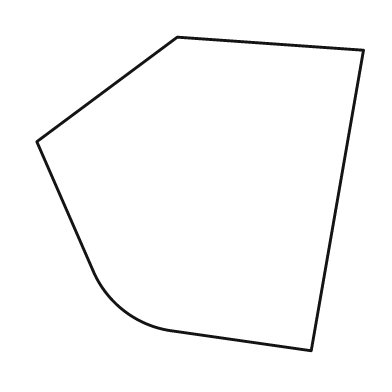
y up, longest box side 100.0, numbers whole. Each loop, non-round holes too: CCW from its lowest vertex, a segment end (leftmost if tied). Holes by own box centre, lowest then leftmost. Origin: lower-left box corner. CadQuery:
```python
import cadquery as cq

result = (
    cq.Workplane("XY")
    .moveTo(84.0, 0.0)
    .lineTo(100.0, 92.0)
    .lineTo(43.0, 96.0)
    .lineTo(0.0, 64.0)
    .lineTo(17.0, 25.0)
    .threePointArc((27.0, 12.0), (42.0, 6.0))
    .close()
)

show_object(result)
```